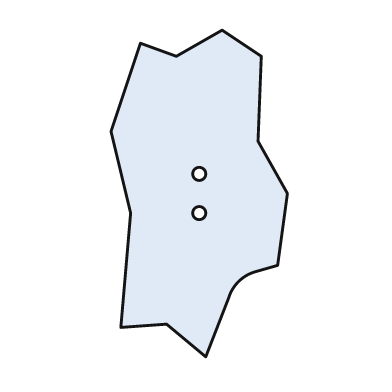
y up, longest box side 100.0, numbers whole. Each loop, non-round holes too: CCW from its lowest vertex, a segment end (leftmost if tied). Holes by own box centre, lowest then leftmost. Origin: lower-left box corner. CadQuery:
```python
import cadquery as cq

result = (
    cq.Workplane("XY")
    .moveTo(29.0, 0.0)
    .lineTo(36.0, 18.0)
    .threePointArc((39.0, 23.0), (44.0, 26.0))
    .lineTo(51.0, 28.0)
    .lineTo(54.0, 50.0)
    .lineTo(45.0, 66.0)
    .lineTo(46.0, 92.0)
    .lineTo(34.0, 100.0)
    .lineTo(20.0, 92.0)
    .lineTo(9.0, 96.0)
    .lineTo(0.0, 69.0)
    .lineTo(6.0, 44.0)
    .lineTo(3.0, 9.0)
    .lineTo(17.0, 10.0)
    .close()
    .moveTo(27.0, 44.0)
    .circle(2.0)
    .moveTo(27.0, 56.0)
    .circle(2.0)
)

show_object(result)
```